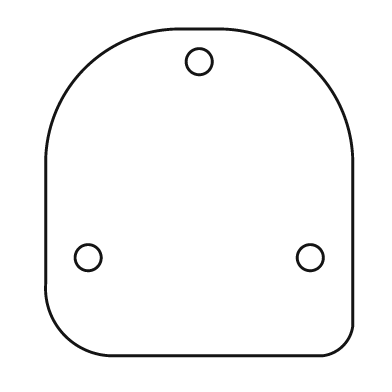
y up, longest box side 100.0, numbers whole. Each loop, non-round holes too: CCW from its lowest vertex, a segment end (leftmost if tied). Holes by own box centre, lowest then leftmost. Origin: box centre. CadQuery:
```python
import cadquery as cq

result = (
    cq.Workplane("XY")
    .moveTo(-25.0, -50.0)
    .lineTo(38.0, -50.0)
    .threePointArc((44.0, -47.0), (47.0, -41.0))
    .lineTo(47.0, 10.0)
    .threePointArc((35.0, 38.0), (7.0, 50.0))
    .lineTo(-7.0, 50.0)
    .threePointArc((-35.0, 38.0), (-47.0, 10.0))
    .lineTo(-47.0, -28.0)
    .threePointArc((-41.0, -44.0), (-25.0, -50.0))
    .close()
    .moveTo(-34.0, -20.0)
    .circle(4.0)
    .moveTo(34.0, -20.0)
    .circle(4.0)
    .moveTo(0.0, 40.0)
    .circle(4.0)
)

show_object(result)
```